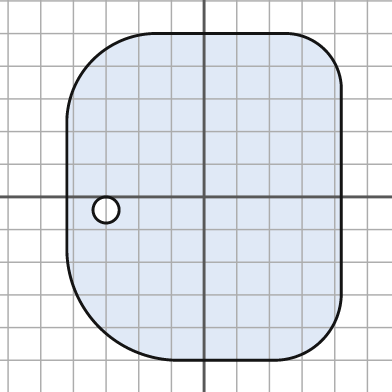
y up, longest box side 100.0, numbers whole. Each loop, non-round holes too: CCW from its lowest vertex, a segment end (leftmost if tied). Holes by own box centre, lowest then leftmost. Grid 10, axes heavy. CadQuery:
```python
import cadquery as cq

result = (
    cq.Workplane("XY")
    .moveTo(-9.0, -50.0)
    .lineTo(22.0, -50.0)
    .threePointArc((36.0, -44.0), (42.0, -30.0))
    .lineTo(42.0, 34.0)
    .threePointArc((37.0, 45.0), (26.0, 50.0))
    .lineTo(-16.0, 50.0)
    .threePointArc((-34.0, 42.0), (-42.0, 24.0))
    .lineTo(-42.0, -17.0)
    .threePointArc((-32.0, -40.0), (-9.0, -50.0))
    .close()
    .moveTo(-30.0, -4.0)
    .circle(4.0)
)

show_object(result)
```